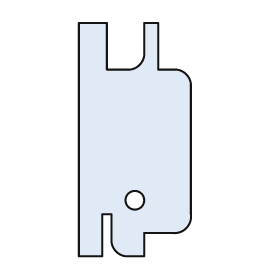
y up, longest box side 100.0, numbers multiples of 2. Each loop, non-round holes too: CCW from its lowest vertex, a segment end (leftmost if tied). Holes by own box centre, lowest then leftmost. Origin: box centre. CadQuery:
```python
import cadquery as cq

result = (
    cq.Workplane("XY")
    .moveTo(-24.0, -50.0)
    .lineTo(-14.0, -50.0)
    .lineTo(-14.0, -32.0)
    .lineTo(-10.0, -32.0)
    .lineTo(-10.0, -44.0)
    .threePointArc((-8.0, -48.0), (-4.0, -50.0))
    .lineTo(4.0, -50.0)
    .lineTo(4.0, -40.0)
    .lineTo(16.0, -40.0)
    .threePointArc((22.0, -38.0), (24.0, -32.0))
    .lineTo(24.0, 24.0)
    .threePointArc((22.0, 28.0), (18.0, 30.0))
    .lineTo(10.0, 30.0)
    .lineTo(10.0, 50.0)
    .lineTo(4.0, 50.0)
    .lineTo(4.0, 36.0)
    .threePointArc((2.0, 32.0), (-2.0, 30.0))
    .lineTo(-12.0, 30.0)
    .lineTo(-12.0, 50.0)
    .lineTo(-24.0, 50.0)
    .close()
    .moveTo(0.0, -26.0)
    .circle(4.0)
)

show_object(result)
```